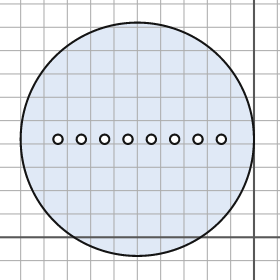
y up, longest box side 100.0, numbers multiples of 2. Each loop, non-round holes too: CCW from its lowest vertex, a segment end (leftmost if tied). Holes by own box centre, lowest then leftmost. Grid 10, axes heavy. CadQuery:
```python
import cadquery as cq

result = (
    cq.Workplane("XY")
    .moveTo(-50.0, 42.0)
    .circle(50.0)
    .moveTo(-84.0, 42.0)
    .circle(2.0)
    .moveTo(-74.0, 42.0)
    .circle(2.0)
    .moveTo(-64.0, 42.0)
    .circle(2.0)
    .moveTo(-54.0, 42.0)
    .circle(2.0)
    .moveTo(-44.0, 42.0)
    .circle(2.0)
    .moveTo(-34.0, 42.0)
    .circle(2.0)
    .moveTo(-24.0, 42.0)
    .circle(2.0)
    .moveTo(-14.0, 42.0)
    .circle(2.0)
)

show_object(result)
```